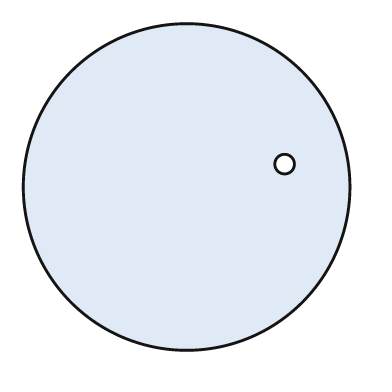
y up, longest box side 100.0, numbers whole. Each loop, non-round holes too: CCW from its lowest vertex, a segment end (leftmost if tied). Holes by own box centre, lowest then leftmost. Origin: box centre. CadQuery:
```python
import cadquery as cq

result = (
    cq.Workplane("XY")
    .moveTo(0.0, 0.0)
    .circle(50.0)
    .moveTo(30.0, 7.0)
    .circle(3.0)
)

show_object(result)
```